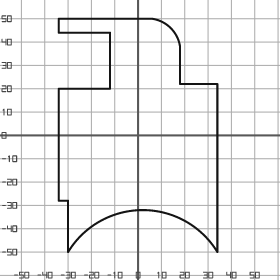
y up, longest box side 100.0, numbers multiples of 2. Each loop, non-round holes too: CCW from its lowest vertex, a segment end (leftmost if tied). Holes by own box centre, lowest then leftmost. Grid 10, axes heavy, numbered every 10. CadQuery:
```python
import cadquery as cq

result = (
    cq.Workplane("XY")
    .moveTo(-30.0, -50.0)
    .threePointArc((2.0, -32.0), (34.0, -50.0))
    .lineTo(34.0, 22.0)
    .lineTo(18.0, 22.0)
    .lineTo(18.0, 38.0)
    .threePointArc((14.0, 46.0), (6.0, 50.0))
    .lineTo(-34.0, 50.0)
    .lineTo(-34.0, 44.0)
    .lineTo(-12.0, 44.0)
    .lineTo(-12.0, 20.0)
    .lineTo(-34.0, 20.0)
    .lineTo(-34.0, -28.0)
    .lineTo(-30.0, -28.0)
    .close()
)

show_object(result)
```